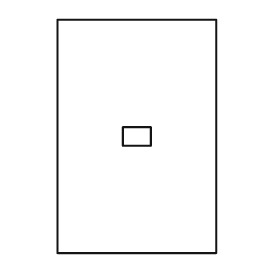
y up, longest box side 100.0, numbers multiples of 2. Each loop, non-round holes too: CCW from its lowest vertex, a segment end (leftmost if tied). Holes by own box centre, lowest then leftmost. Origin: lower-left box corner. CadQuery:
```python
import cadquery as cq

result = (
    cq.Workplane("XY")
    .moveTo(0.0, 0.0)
    .lineTo(68.0, 0.0)
    .lineTo(68.0, 100.0)
    .lineTo(0.0, 100.0)
    .close()
    .moveTo(28.0, 46.0)
    .lineTo(40.0, 46.0)
    .lineTo(40.0, 54.0)
    .lineTo(28.0, 54.0)
    .close()
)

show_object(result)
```